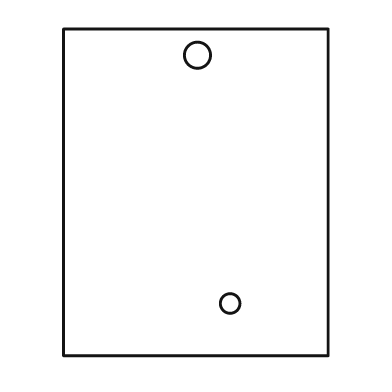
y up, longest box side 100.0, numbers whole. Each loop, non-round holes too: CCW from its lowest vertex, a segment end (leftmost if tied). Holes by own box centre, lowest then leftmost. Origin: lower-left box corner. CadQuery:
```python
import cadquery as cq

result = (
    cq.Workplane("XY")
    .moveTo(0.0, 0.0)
    .lineTo(81.0, 0.0)
    .lineTo(81.0, 100.0)
    .lineTo(0.0, 100.0)
    .close()
    .moveTo(51.0, 16.0)
    .circle(3.0)
    .moveTo(41.0, 92.0)
    .circle(4.0)
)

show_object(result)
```